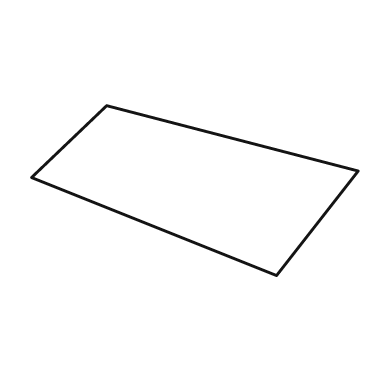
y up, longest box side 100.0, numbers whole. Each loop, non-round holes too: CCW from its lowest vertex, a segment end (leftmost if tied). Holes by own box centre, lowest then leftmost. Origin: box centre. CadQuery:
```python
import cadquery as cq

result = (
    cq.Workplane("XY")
    .moveTo(25.0, -26.0)
    .lineTo(50.0, 6.0)
    .lineTo(-27.0, 26.0)
    .lineTo(-50.0, 4.0)
    .close()
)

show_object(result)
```